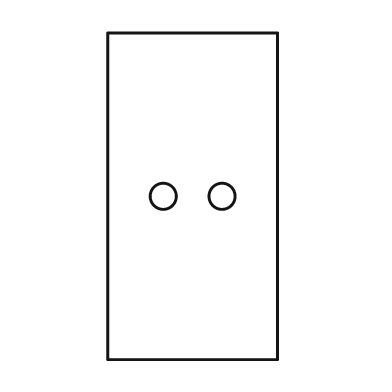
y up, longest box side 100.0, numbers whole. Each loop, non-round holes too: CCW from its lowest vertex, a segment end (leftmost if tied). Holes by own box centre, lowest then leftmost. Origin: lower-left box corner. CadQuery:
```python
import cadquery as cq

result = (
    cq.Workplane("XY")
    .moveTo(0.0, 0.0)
    .lineTo(52.0, 0.0)
    .lineTo(52.0, 100.0)
    .lineTo(0.0, 100.0)
    .close()
    .moveTo(17.0, 50.0)
    .circle(4.0)
    .moveTo(35.0, 50.0)
    .circle(4.0)
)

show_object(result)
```